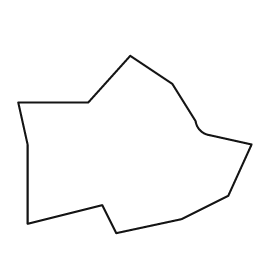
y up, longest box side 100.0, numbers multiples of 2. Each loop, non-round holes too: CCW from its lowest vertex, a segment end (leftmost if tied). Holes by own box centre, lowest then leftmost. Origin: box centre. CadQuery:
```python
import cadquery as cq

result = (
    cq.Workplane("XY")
    .moveTo(-8.0, -38.0)
    .lineTo(20.0, -32.0)
    .lineTo(40.0, -22.0)
    .lineTo(50.0, 0.0)
    .lineTo(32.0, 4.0)
    .threePointArc((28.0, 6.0), (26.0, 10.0))
    .lineTo(16.0, 26.0)
    .lineTo(-2.0, 38.0)
    .lineTo(-20.0, 18.0)
    .lineTo(-50.0, 18.0)
    .lineTo(-46.0, 0.0)
    .lineTo(-46.0, -34.0)
    .lineTo(-14.0, -26.0)
    .close()
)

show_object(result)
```